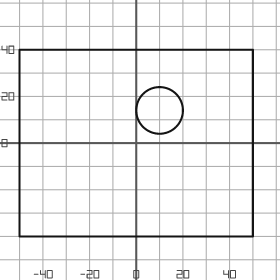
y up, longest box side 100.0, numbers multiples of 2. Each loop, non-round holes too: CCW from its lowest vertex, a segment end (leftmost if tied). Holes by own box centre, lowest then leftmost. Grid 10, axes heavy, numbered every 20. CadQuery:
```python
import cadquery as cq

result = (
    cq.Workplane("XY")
    .moveTo(-50.0, -40.0)
    .lineTo(50.0, -40.0)
    .lineTo(50.0, 40.0)
    .lineTo(-50.0, 40.0)
    .close()
    .moveTo(10.0, 14.0)
    .circle(10.0)
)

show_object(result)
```